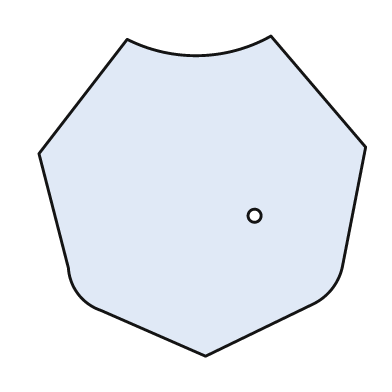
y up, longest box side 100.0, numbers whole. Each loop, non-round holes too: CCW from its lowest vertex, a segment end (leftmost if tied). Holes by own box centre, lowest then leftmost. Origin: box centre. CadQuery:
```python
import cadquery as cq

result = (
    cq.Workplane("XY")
    .moveTo(1.0, -49.0)
    .lineTo(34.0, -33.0)
    .threePointArc((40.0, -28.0), (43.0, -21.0))
    .lineTo(50.0, 15.0)
    .lineTo(21.0, 49.0)
    .threePointArc((-1.0, 43.0), (-23.0, 48.0))
    .lineTo(-50.0, 13.0)
    .lineTo(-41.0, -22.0)
    .threePointArc((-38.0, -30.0), (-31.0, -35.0))
    .close()
    .moveTo(16.0, -6.0)
    .circle(2.0)
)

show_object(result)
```